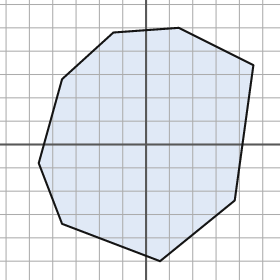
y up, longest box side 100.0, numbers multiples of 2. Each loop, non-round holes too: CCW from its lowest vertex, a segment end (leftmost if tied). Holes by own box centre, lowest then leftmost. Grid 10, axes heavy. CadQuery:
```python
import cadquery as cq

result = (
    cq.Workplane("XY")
    .moveTo(6.0, -50.0)
    .lineTo(38.0, -24.0)
    .lineTo(46.0, 34.0)
    .lineTo(14.0, 50.0)
    .lineTo(-14.0, 48.0)
    .lineTo(-36.0, 28.0)
    .lineTo(-46.0, -8.0)
    .lineTo(-36.0, -34.0)
    .close()
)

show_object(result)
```